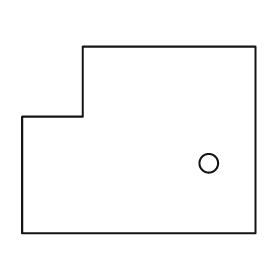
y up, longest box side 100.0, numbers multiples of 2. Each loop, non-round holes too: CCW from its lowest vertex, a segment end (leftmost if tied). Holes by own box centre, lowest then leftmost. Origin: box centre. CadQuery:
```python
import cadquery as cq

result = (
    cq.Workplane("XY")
    .moveTo(-50.0, -40.0)
    .lineTo(50.0, -40.0)
    .lineTo(50.0, 40.0)
    .lineTo(-24.0, 40.0)
    .lineTo(-24.0, 10.0)
    .lineTo(-50.0, 10.0)
    .close()
    .moveTo(30.0, -10.0)
    .circle(4.0)
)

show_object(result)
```